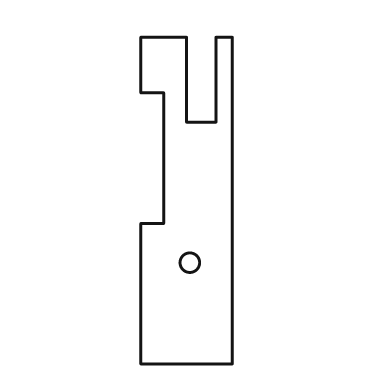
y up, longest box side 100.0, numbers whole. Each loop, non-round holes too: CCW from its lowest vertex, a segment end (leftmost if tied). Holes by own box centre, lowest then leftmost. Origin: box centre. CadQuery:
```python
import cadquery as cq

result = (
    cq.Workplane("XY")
    .moveTo(-14.0, -50.0)
    .lineTo(14.0, -50.0)
    .lineTo(14.0, 50.0)
    .lineTo(9.0, 50.0)
    .lineTo(9.0, 24.0)
    .lineTo(0.0, 24.0)
    .lineTo(0.0, 50.0)
    .lineTo(-14.0, 50.0)
    .lineTo(-14.0, 33.0)
    .lineTo(-7.0, 33.0)
    .lineTo(-7.0, -7.0)
    .lineTo(-14.0, -7.0)
    .close()
    .moveTo(1.0, -19.0)
    .circle(3.0)
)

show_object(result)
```